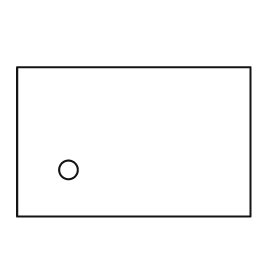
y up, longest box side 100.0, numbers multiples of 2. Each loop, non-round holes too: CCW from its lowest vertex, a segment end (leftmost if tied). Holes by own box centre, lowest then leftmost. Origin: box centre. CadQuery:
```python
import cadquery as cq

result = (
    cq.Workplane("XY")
    .moveTo(-50.0, -32.0)
    .lineTo(50.0, -32.0)
    .lineTo(50.0, 32.0)
    .lineTo(-50.0, 32.0)
    .close()
    .moveTo(-28.0, -12.0)
    .circle(4.0)
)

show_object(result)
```